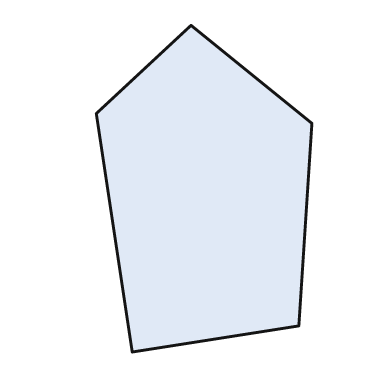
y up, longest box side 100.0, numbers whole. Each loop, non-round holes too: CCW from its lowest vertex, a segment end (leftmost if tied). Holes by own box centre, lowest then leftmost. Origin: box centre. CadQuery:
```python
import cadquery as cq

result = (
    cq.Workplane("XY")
    .moveTo(-22.0, -50.0)
    .lineTo(29.0, -42.0)
    .lineTo(33.0, 20.0)
    .lineTo(-4.0, 50.0)
    .lineTo(-33.0, 23.0)
    .close()
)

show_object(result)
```